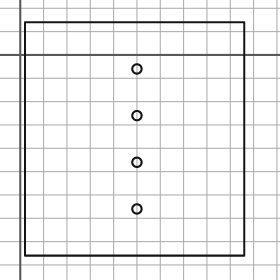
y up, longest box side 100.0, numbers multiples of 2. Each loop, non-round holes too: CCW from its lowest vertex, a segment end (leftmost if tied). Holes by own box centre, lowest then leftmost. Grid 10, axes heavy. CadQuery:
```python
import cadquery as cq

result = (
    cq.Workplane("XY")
    .moveTo(2.0, -86.0)
    .lineTo(96.0, -86.0)
    .lineTo(96.0, 14.0)
    .lineTo(2.0, 14.0)
    .close()
    .moveTo(50.0, -66.0)
    .circle(2.0)
    .moveTo(50.0, -46.0)
    .circle(2.0)
    .moveTo(50.0, -26.0)
    .circle(2.0)
    .moveTo(50.0, -6.0)
    .circle(2.0)
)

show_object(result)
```